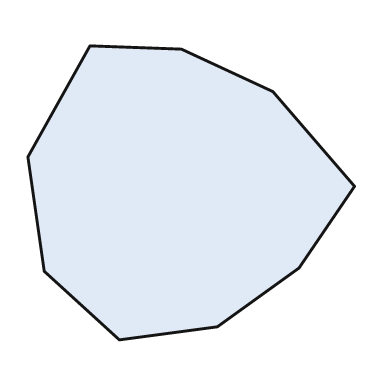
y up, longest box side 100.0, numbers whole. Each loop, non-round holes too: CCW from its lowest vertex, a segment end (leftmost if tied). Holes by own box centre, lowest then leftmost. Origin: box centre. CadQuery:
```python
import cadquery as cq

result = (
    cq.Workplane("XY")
    .moveTo(-22.0, -45.0)
    .lineTo(8.0, -41.0)
    .lineTo(33.0, -23.0)
    .lineTo(50.0, 2.0)
    .lineTo(25.0, 31.0)
    .lineTo(-3.0, 44.0)
    .lineTo(-31.0, 45.0)
    .lineTo(-50.0, 11.0)
    .lineTo(-45.0, -24.0)
    .close()
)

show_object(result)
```